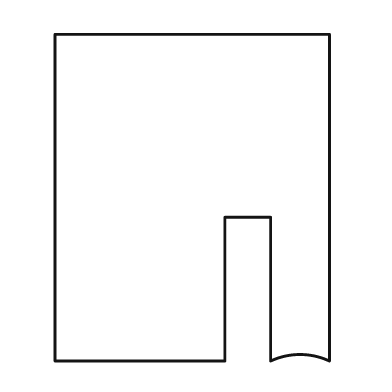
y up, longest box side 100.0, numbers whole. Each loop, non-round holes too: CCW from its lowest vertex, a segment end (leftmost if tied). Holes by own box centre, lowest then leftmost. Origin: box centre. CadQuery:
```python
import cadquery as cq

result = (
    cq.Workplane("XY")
    .moveTo(-42.0, -50.0)
    .lineTo(10.0, -50.0)
    .lineTo(10.0, -6.0)
    .lineTo(24.0, -6.0)
    .lineTo(24.0, -50.0)
    .threePointArc((33.0, -48.0), (42.0, -50.0))
    .lineTo(42.0, 50.0)
    .lineTo(-42.0, 50.0)
    .close()
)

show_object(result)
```